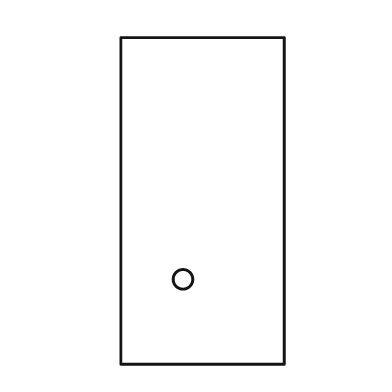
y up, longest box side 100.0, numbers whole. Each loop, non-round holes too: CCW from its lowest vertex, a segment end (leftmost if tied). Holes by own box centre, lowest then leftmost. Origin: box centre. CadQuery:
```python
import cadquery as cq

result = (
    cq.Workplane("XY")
    .moveTo(-25.0, -50.0)
    .lineTo(25.0, -50.0)
    .lineTo(25.0, 50.0)
    .lineTo(-25.0, 50.0)
    .close()
    .moveTo(-6.0, -24.0)
    .circle(3.0)
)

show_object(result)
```